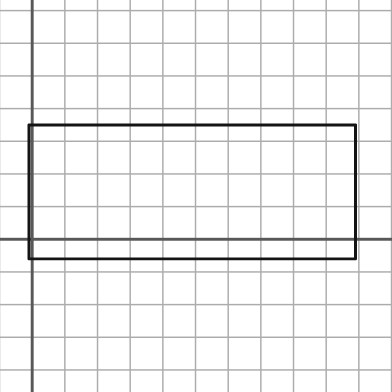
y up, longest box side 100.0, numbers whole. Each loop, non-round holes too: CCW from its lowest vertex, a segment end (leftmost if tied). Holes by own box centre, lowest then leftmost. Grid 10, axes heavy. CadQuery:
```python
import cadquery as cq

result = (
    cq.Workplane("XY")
    .moveTo(-1.0, -6.0)
    .lineTo(99.0, -6.0)
    .lineTo(99.0, 35.0)
    .lineTo(-1.0, 35.0)
    .close()
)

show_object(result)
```